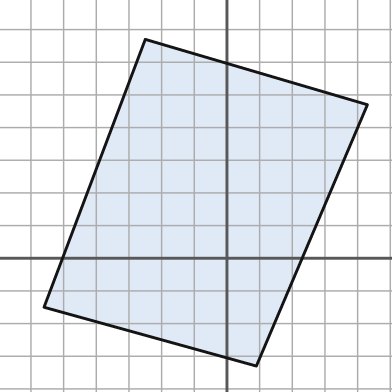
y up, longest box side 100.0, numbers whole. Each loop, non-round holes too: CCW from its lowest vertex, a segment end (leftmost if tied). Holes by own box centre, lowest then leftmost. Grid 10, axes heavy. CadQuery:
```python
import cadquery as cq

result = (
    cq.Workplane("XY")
    .moveTo(9.0, -33.0)
    .lineTo(43.0, 47.0)
    .lineTo(-25.0, 67.0)
    .lineTo(-56.0, -15.0)
    .close()
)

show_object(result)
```